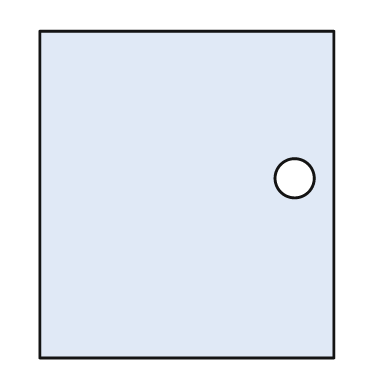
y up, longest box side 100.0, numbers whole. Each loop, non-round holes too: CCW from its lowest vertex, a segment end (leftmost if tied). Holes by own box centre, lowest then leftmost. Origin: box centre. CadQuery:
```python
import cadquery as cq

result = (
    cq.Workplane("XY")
    .moveTo(-45.0, -50.0)
    .lineTo(45.0, -50.0)
    .lineTo(45.0, 50.0)
    .lineTo(-45.0, 50.0)
    .close()
    .moveTo(33.0, 5.0)
    .circle(6.0)
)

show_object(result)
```